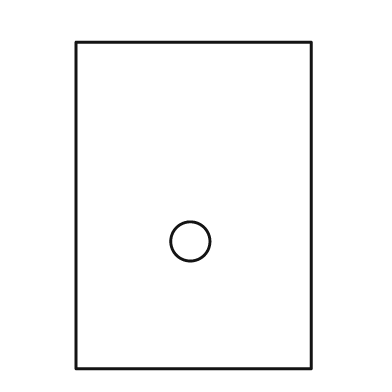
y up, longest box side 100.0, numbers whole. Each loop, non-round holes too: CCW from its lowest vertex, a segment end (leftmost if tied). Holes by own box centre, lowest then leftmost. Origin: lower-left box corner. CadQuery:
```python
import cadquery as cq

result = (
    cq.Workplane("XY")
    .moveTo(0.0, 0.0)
    .lineTo(72.0, 0.0)
    .lineTo(72.0, 100.0)
    .lineTo(0.0, 100.0)
    .close()
    .moveTo(35.0, 39.0)
    .circle(6.0)
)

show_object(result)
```